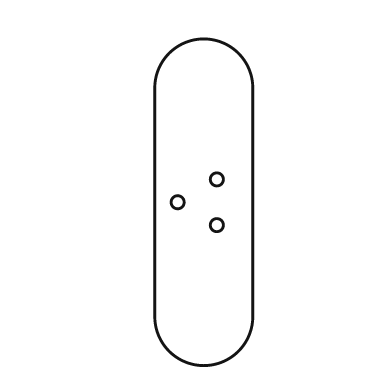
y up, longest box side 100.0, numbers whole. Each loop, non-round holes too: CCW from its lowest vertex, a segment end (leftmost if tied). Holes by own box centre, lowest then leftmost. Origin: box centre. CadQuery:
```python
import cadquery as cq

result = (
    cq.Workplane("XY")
    .moveTo(-15.0, -35.0)
    .threePointArc((0.0, -50.0), (15.0, -35.0))
    .lineTo(15.0, 35.0)
    .threePointArc((0.0, 50.0), (-15.0, 35.0))
    .close()
    .moveTo(4.0, -7.0)
    .circle(2.0)
    .moveTo(-8.0, 0.0)
    .circle(2.0)
    .moveTo(4.0, 7.0)
    .circle(2.0)
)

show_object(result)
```